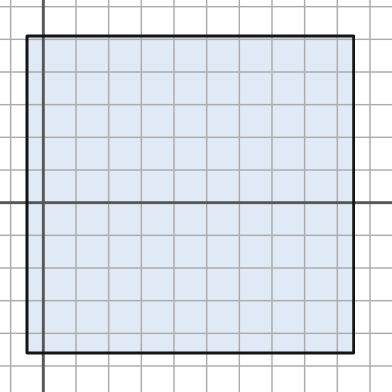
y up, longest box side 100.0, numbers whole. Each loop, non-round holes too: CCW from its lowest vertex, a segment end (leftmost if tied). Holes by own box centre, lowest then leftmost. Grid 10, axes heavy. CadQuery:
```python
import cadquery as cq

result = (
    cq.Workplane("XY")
    .moveTo(-5.0, -46.0)
    .lineTo(95.0, -46.0)
    .lineTo(95.0, 51.0)
    .lineTo(-5.0, 51.0)
    .close()
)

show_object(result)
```